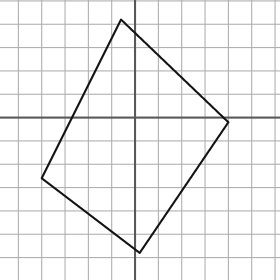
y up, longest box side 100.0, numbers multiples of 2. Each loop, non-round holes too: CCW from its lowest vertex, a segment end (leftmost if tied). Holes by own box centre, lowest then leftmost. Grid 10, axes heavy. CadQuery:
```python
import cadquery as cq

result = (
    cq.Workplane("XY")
    .moveTo(2.0, -58.0)
    .lineTo(40.0, -2.0)
    .lineTo(-6.0, 42.0)
    .lineTo(-40.0, -26.0)
    .close()
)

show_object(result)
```